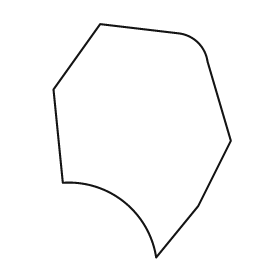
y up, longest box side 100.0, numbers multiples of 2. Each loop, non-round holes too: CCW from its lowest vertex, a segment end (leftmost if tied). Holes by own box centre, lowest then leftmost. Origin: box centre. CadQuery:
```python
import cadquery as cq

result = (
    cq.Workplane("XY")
    .moveTo(6.0, -50.0)
    .lineTo(24.0, -28.0)
    .lineTo(38.0, 0.0)
    .lineTo(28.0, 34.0)
    .threePointArc((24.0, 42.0), (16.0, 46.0))
    .lineTo(-18.0, 50.0)
    .lineTo(-38.0, 22.0)
    .lineTo(-34.0, -18.0)
    .threePointArc((-8.0, -26.0), (6.0, -50.0))
    .close()
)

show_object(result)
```